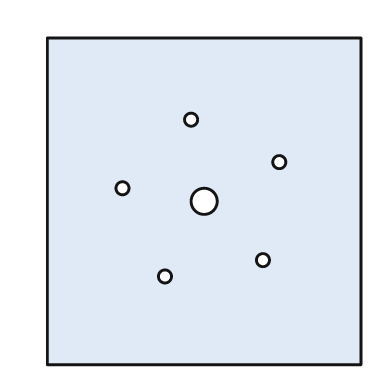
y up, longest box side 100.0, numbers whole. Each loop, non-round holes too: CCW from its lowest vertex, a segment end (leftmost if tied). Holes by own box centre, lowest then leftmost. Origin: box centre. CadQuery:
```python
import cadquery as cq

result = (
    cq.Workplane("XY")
    .moveTo(-48.0, -50.0)
    .lineTo(48.0, -50.0)
    .lineTo(48.0, 50.0)
    .lineTo(-48.0, 50.0)
    .close()
    .moveTo(-12.0, -23.0)
    .circle(2.0)
    .moveTo(18.0, -18.0)
    .circle(2.0)
    .moveTo(0.0, 0.0)
    .circle(4.0)
    .moveTo(-25.0, 4.0)
    .circle(2.0)
    .moveTo(23.0, 12.0)
    .circle(2.0)
    .moveTo(-4.0, 25.0)
    .circle(2.0)
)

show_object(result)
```